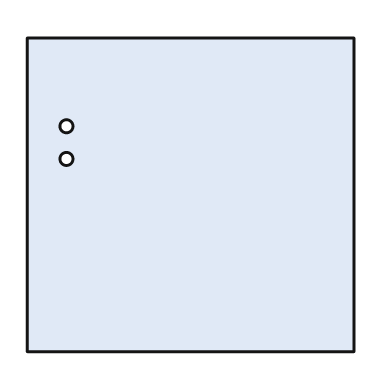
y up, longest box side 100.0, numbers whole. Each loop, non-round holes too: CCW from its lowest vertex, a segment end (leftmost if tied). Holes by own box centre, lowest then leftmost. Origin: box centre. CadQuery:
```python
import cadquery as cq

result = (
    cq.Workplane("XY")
    .moveTo(-50.0, -48.0)
    .lineTo(50.0, -48.0)
    .lineTo(50.0, 48.0)
    .lineTo(-50.0, 48.0)
    .close()
    .moveTo(-38.0, 11.0)
    .circle(2.0)
    .moveTo(-38.0, 21.0)
    .circle(2.0)
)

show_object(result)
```